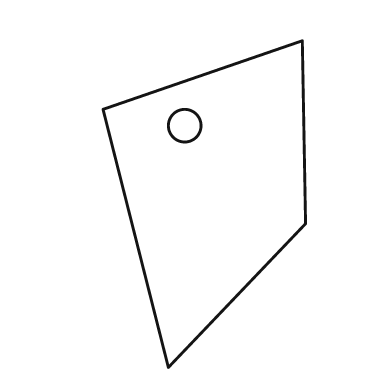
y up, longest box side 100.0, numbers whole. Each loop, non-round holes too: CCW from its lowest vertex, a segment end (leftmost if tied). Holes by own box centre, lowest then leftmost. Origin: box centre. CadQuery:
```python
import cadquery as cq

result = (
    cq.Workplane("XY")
    .moveTo(-11.0, -50.0)
    .lineTo(31.0, -6.0)
    .lineTo(30.0, 50.0)
    .lineTo(-31.0, 29.0)
    .close()
    .moveTo(-6.0, 24.0)
    .circle(5.0)
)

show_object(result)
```